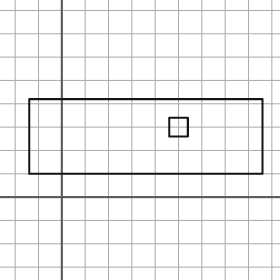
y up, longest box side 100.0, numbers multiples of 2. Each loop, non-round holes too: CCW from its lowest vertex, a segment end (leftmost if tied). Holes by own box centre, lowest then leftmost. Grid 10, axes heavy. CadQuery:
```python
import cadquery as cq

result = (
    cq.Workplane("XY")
    .moveTo(-14.0, 10.0)
    .lineTo(86.0, 10.0)
    .lineTo(86.0, 42.0)
    .lineTo(-14.0, 42.0)
    .close()
    .moveTo(46.0, 26.0)
    .lineTo(54.0, 26.0)
    .lineTo(54.0, 34.0)
    .lineTo(46.0, 34.0)
    .close()
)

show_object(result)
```